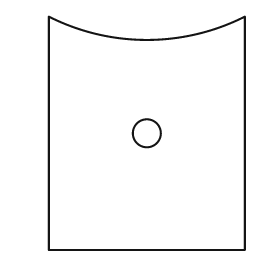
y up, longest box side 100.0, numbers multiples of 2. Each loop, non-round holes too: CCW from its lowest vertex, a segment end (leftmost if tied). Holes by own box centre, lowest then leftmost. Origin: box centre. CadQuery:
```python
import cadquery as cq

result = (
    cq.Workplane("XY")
    .moveTo(-42.0, -50.0)
    .lineTo(42.0, -50.0)
    .lineTo(42.0, 50.0)
    .threePointArc((0.0, 40.0), (-42.0, 50.0))
    .close()
    .moveTo(0.0, 0.0)
    .circle(6.0)
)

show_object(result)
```